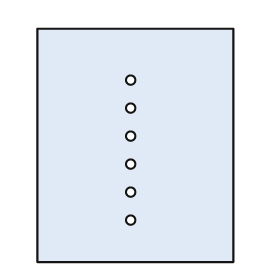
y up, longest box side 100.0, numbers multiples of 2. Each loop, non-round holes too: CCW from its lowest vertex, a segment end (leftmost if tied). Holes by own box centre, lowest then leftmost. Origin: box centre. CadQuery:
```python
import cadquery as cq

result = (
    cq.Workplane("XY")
    .moveTo(-42.0, -50.0)
    .lineTo(42.0, -50.0)
    .lineTo(42.0, 50.0)
    .lineTo(-42.0, 50.0)
    .close()
    .moveTo(-2.0, -32.0)
    .circle(2.0)
    .moveTo(-2.0, -20.0)
    .circle(2.0)
    .moveTo(-2.0, -8.0)
    .circle(2.0)
    .moveTo(-2.0, 4.0)
    .circle(2.0)
    .moveTo(-2.0, 16.0)
    .circle(2.0)
    .moveTo(-2.0, 28.0)
    .circle(2.0)
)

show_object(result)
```